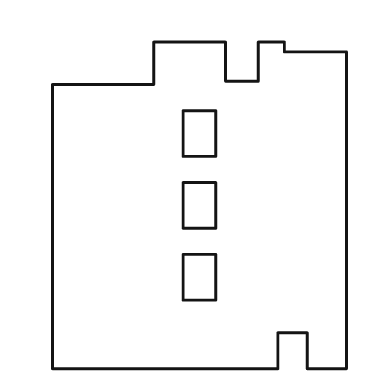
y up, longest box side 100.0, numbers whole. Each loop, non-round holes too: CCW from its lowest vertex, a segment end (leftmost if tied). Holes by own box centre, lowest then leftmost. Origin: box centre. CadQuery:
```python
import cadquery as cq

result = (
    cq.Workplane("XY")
    .moveTo(-45.0, -50.0)
    .lineTo(24.0, -50.0)
    .lineTo(24.0, -39.0)
    .lineTo(33.0, -39.0)
    .lineTo(33.0, -50.0)
    .lineTo(45.0, -50.0)
    .lineTo(45.0, 47.0)
    .lineTo(26.0, 47.0)
    .lineTo(26.0, 50.0)
    .lineTo(18.0, 50.0)
    .lineTo(18.0, 38.0)
    .lineTo(8.0, 38.0)
    .lineTo(8.0, 50.0)
    .lineTo(-14.0, 50.0)
    .lineTo(-14.0, 37.0)
    .lineTo(-45.0, 37.0)
    .close()
    .moveTo(-5.0, -29.0)
    .lineTo(5.0, -29.0)
    .lineTo(5.0, -15.0)
    .lineTo(-5.0, -15.0)
    .close()
    .moveTo(-5.0, -7.0)
    .lineTo(5.0, -7.0)
    .lineTo(5.0, 7.0)
    .lineTo(-5.0, 7.0)
    .close()
    .moveTo(-5.0, 15.0)
    .lineTo(5.0, 15.0)
    .lineTo(5.0, 29.0)
    .lineTo(-5.0, 29.0)
    .close()
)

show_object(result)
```